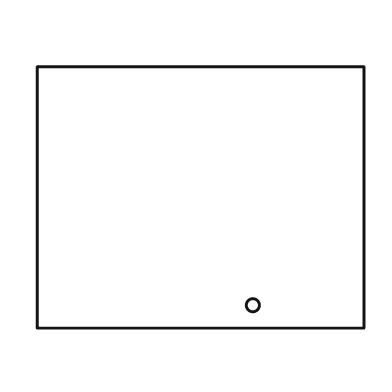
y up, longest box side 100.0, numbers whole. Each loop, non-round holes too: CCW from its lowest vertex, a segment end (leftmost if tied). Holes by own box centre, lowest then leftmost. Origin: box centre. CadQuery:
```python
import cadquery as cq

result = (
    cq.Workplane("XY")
    .moveTo(-50.0, -40.0)
    .lineTo(50.0, -40.0)
    .lineTo(50.0, 40.0)
    .lineTo(-50.0, 40.0)
    .close()
    .moveTo(16.0, -33.0)
    .circle(2.0)
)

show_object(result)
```